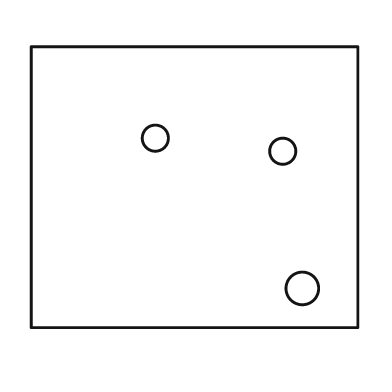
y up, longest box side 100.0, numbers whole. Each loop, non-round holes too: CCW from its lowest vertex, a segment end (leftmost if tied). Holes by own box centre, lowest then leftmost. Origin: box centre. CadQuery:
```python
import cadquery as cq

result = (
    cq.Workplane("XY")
    .moveTo(-50.0, -43.0)
    .lineTo(50.0, -43.0)
    .lineTo(50.0, 43.0)
    .lineTo(-50.0, 43.0)
    .close()
    .moveTo(33.0, -31.0)
    .circle(5.0)
    .moveTo(27.0, 11.0)
    .circle(4.0)
    .moveTo(-12.0, 15.0)
    .circle(4.0)
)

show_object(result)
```